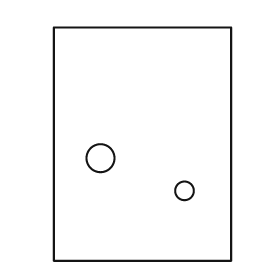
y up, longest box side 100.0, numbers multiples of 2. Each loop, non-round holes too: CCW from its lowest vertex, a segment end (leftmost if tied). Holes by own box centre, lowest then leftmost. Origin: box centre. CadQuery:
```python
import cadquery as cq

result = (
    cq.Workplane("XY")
    .moveTo(-38.0, -50.0)
    .lineTo(38.0, -50.0)
    .lineTo(38.0, 50.0)
    .lineTo(-38.0, 50.0)
    .close()
    .moveTo(18.0, -20.0)
    .circle(4.0)
    .moveTo(-18.0, -6.0)
    .circle(6.0)
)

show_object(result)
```